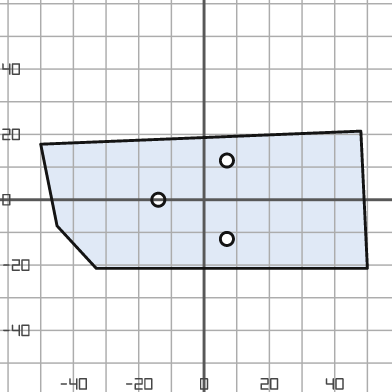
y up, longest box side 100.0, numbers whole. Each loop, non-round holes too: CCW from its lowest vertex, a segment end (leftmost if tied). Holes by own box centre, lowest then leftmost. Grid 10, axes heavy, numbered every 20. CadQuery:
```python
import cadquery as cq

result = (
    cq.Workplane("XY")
    .moveTo(-33.0, -21.0)
    .lineTo(50.0, -21.0)
    .lineTo(48.0, 21.0)
    .lineTo(-50.0, 17.0)
    .lineTo(-45.0, -8.0)
    .close()
    .moveTo(7.0, -12.0)
    .circle(2.0)
    .moveTo(-14.0, 0.0)
    .circle(2.0)
    .moveTo(7.0, 12.0)
    .circle(2.0)
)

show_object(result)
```